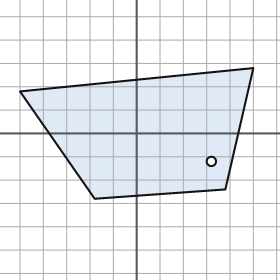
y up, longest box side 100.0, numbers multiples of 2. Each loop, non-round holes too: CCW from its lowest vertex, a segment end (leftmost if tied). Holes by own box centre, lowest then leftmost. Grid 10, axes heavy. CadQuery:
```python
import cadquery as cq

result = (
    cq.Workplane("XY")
    .moveTo(-18.0, -28.0)
    .lineTo(38.0, -24.0)
    .lineTo(50.0, 28.0)
    .lineTo(-50.0, 18.0)
    .close()
    .moveTo(32.0, -12.0)
    .circle(2.0)
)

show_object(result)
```